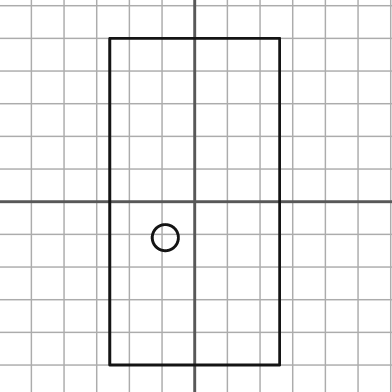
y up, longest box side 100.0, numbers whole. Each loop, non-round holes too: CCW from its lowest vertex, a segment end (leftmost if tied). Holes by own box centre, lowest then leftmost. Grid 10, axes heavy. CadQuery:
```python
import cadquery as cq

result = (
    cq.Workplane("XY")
    .moveTo(-26.0, -50.0)
    .lineTo(26.0, -50.0)
    .lineTo(26.0, 50.0)
    .lineTo(-26.0, 50.0)
    .close()
    .moveTo(-9.0, -11.0)
    .circle(4.0)
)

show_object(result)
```